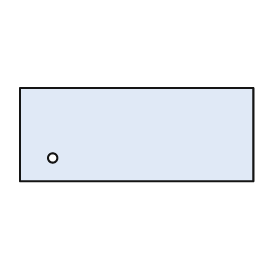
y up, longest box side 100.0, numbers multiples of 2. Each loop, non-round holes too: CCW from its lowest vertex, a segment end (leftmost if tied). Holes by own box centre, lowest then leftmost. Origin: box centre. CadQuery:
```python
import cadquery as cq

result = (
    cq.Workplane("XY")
    .moveTo(-50.0, -20.0)
    .lineTo(50.0, -20.0)
    .lineTo(50.0, 20.0)
    .lineTo(-50.0, 20.0)
    .close()
    .moveTo(-36.0, -10.0)
    .circle(2.0)
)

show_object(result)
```